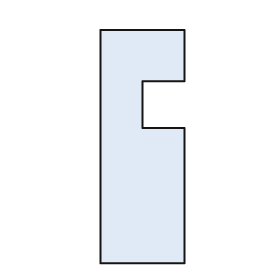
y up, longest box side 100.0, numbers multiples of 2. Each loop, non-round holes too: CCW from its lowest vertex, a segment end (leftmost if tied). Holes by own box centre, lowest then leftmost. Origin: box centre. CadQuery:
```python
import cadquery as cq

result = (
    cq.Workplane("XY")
    .moveTo(-18.0, -50.0)
    .lineTo(18.0, -50.0)
    .lineTo(18.0, 8.0)
    .lineTo(0.0, 8.0)
    .lineTo(0.0, 28.0)
    .lineTo(18.0, 28.0)
    .lineTo(18.0, 50.0)
    .lineTo(-18.0, 50.0)
    .close()
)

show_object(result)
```